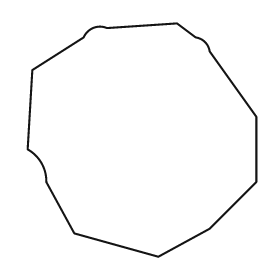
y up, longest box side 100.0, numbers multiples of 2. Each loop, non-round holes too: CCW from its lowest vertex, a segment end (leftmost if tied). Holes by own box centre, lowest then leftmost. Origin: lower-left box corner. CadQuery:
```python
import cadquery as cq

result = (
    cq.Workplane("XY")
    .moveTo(56.0, 0.0)
    .lineTo(78.0, 12.0)
    .lineTo(98.0, 32.0)
    .lineTo(98.0, 60.0)
    .lineTo(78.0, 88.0)
    .threePointArc((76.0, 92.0), (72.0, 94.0))
    .lineTo(64.0, 100.0)
    .lineTo(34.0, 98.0)
    .threePointArc((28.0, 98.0), (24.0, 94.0))
    .lineTo(2.0, 80.0)
    .lineTo(0.0, 46.0)
    .threePointArc((6.0, 40.0), (8.0, 32.0))
    .lineTo(20.0, 10.0)
    .close()
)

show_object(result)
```